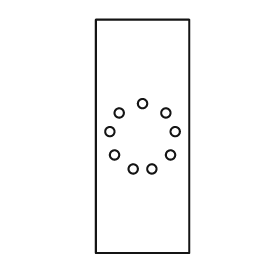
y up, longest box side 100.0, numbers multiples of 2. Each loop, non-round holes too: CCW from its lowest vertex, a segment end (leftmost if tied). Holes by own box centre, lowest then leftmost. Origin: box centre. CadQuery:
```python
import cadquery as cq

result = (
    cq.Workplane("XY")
    .moveTo(-20.0, -50.0)
    .lineTo(20.0, -50.0)
    .lineTo(20.0, 50.0)
    .lineTo(-20.0, 50.0)
    .close()
    .moveTo(-4.0, -14.0)
    .circle(2.0)
    .moveTo(4.0, -14.0)
    .circle(2.0)
    .moveTo(-12.0, -8.0)
    .circle(2.0)
    .moveTo(12.0, -8.0)
    .circle(2.0)
    .moveTo(-14.0, 2.0)
    .circle(2.0)
    .moveTo(14.0, 2.0)
    .circle(2.0)
    .moveTo(-10.0, 10.0)
    .circle(2.0)
    .moveTo(10.0, 10.0)
    .circle(2.0)
    .moveTo(0.0, 14.0)
    .circle(2.0)
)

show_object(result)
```